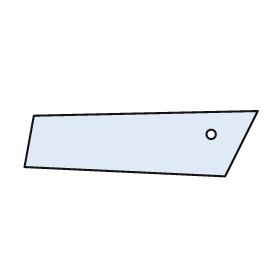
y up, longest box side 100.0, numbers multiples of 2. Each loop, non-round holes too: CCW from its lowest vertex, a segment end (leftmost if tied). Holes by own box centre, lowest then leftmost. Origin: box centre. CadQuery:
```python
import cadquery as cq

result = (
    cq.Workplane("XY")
    .moveTo(36.0, -14.0)
    .lineTo(50.0, 14.0)
    .lineTo(-46.0, 12.0)
    .lineTo(-50.0, -10.0)
    .close()
    .moveTo(30.0, 4.0)
    .circle(2.0)
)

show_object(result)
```